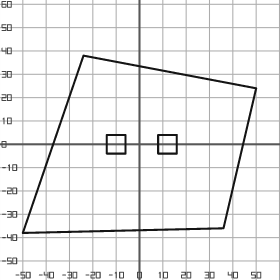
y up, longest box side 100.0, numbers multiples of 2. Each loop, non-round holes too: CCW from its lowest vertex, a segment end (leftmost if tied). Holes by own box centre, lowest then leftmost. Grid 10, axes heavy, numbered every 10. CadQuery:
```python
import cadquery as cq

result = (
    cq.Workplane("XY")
    .moveTo(-50.0, -38.0)
    .lineTo(36.0, -36.0)
    .lineTo(50.0, 24.0)
    .lineTo(-24.0, 38.0)
    .close()
    .moveTo(-14.0, -4.0)
    .lineTo(-6.0, -4.0)
    .lineTo(-6.0, 4.0)
    .lineTo(-14.0, 4.0)
    .close()
    .moveTo(8.0, -4.0)
    .lineTo(16.0, -4.0)
    .lineTo(16.0, 4.0)
    .lineTo(8.0, 4.0)
    .close()
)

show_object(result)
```